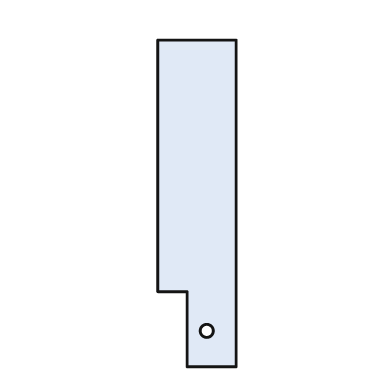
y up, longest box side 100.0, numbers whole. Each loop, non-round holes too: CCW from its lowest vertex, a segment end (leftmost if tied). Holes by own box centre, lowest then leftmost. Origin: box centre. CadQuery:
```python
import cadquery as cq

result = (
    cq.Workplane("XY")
    .moveTo(-3.0, -50.0)
    .lineTo(12.0, -50.0)
    .lineTo(12.0, 50.0)
    .lineTo(-12.0, 50.0)
    .lineTo(-12.0, -27.0)
    .lineTo(-3.0, -27.0)
    .close()
    .moveTo(3.0, -39.0)
    .circle(2.0)
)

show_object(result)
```